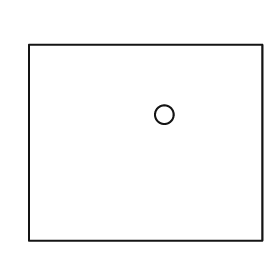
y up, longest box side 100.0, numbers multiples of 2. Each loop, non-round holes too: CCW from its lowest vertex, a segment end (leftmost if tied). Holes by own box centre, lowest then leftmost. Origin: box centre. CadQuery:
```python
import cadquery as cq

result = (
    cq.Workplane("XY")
    .moveTo(-50.0, -42.0)
    .lineTo(50.0, -42.0)
    .lineTo(50.0, 42.0)
    .lineTo(-50.0, 42.0)
    .close()
    .moveTo(8.0, 12.0)
    .circle(4.0)
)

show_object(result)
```